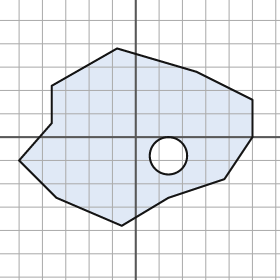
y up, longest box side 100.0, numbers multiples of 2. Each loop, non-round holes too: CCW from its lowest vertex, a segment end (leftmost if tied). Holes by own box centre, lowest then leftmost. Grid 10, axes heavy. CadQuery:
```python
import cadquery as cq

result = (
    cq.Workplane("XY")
    .moveTo(-6.0, -38.0)
    .lineTo(14.0, -26.0)
    .lineTo(38.0, -18.0)
    .lineTo(50.0, 0.0)
    .lineTo(50.0, 16.0)
    .lineTo(26.0, 28.0)
    .lineTo(-8.0, 38.0)
    .lineTo(-36.0, 22.0)
    .lineTo(-36.0, 6.0)
    .lineTo(-50.0, -10.0)
    .lineTo(-34.0, -26.0)
    .close()
    .moveTo(14.0, -8.0)
    .circle(8.0)
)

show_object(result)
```